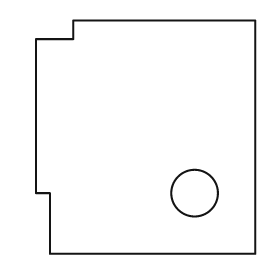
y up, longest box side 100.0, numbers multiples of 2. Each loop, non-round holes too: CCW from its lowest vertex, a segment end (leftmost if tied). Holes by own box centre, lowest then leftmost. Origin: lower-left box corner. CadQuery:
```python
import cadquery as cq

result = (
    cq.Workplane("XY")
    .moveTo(6.0, 0.0)
    .lineTo(94.0, 0.0)
    .lineTo(94.0, 100.0)
    .lineTo(16.0, 100.0)
    .lineTo(16.0, 92.0)
    .lineTo(0.0, 92.0)
    .lineTo(0.0, 26.0)
    .lineTo(6.0, 26.0)
    .close()
    .moveTo(68.0, 26.0)
    .circle(10.0)
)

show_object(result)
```